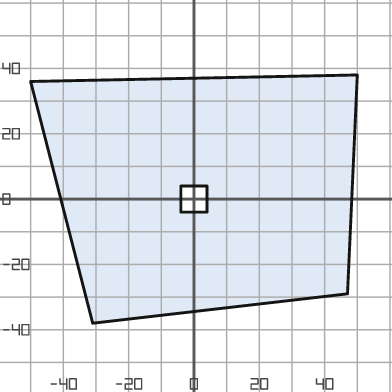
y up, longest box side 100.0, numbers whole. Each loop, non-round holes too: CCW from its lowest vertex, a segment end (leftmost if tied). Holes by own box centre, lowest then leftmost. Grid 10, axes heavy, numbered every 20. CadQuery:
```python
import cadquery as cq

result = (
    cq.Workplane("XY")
    .moveTo(-31.0, -38.0)
    .lineTo(47.0, -29.0)
    .lineTo(50.0, 38.0)
    .lineTo(-50.0, 36.0)
    .close()
    .moveTo(-4.0, -4.0)
    .lineTo(4.0, -4.0)
    .lineTo(4.0, 4.0)
    .lineTo(-4.0, 4.0)
    .close()
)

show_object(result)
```